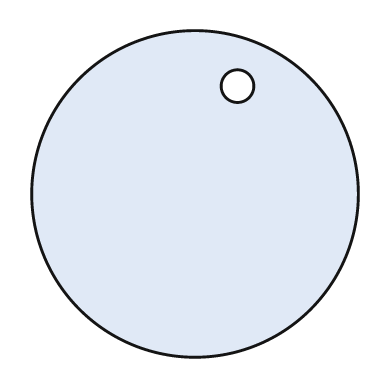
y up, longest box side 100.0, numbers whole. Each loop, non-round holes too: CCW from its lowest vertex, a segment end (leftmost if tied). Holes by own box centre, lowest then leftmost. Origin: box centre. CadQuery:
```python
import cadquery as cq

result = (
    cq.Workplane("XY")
    .moveTo(0.0, 0.0)
    .circle(50.0)
    .moveTo(13.0, 33.0)
    .circle(5.0)
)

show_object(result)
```